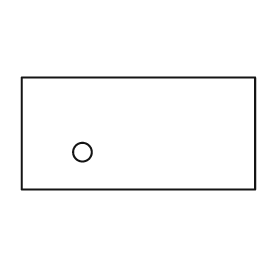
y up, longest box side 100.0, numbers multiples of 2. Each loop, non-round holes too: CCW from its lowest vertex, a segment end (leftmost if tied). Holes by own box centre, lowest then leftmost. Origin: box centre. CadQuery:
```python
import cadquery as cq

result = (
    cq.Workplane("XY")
    .moveTo(-50.0, -24.0)
    .lineTo(50.0, -24.0)
    .lineTo(50.0, 24.0)
    .lineTo(-50.0, 24.0)
    .close()
    .moveTo(-24.0, -8.0)
    .circle(4.0)
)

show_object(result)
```